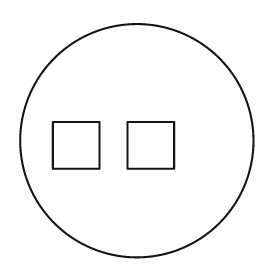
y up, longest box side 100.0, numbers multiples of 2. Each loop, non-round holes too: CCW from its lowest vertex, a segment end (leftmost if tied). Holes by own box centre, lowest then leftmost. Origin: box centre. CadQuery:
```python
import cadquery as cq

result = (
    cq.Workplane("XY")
    .moveTo(0.0, 0.0)
    .circle(50.0)
    .moveTo(-36.0, -12.0)
    .lineTo(-16.0, -12.0)
    .lineTo(-16.0, 8.0)
    .lineTo(-36.0, 8.0)
    .close()
    .moveTo(-4.0, -12.0)
    .lineTo(16.0, -12.0)
    .lineTo(16.0, 8.0)
    .lineTo(-4.0, 8.0)
    .close()
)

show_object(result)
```